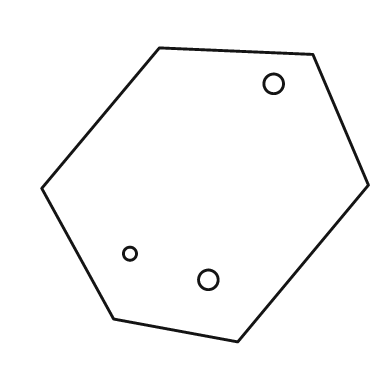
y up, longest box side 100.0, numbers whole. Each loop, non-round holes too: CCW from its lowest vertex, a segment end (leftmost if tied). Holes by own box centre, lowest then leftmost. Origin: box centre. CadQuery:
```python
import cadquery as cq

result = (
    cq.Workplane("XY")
    .moveTo(10.0, -45.0)
    .lineTo(50.0, 3.0)
    .lineTo(33.0, 43.0)
    .lineTo(-14.0, 45.0)
    .lineTo(-50.0, 2.0)
    .lineTo(-28.0, -38.0)
    .close()
    .moveTo(1.0, -26.0)
    .circle(3.0)
    .moveTo(-23.0, -18.0)
    .circle(2.0)
    .moveTo(21.0, 34.0)
    .circle(3.0)
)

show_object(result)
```